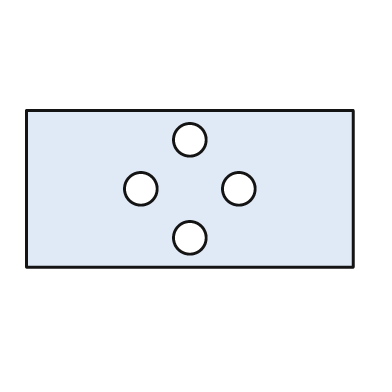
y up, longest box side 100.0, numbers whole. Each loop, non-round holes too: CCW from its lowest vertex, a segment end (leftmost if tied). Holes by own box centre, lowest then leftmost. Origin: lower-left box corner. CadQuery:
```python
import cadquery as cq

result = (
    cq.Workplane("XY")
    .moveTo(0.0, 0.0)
    .lineTo(100.0, 0.0)
    .lineTo(100.0, 48.0)
    .lineTo(0.0, 48.0)
    .close()
    .moveTo(50.0, 9.0)
    .circle(5.0)
    .moveTo(35.0, 24.0)
    .circle(5.0)
    .moveTo(65.0, 24.0)
    .circle(5.0)
    .moveTo(50.0, 39.0)
    .circle(5.0)
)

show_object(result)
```